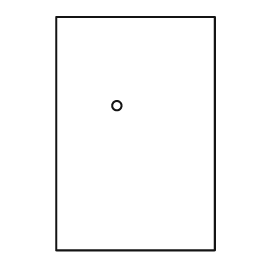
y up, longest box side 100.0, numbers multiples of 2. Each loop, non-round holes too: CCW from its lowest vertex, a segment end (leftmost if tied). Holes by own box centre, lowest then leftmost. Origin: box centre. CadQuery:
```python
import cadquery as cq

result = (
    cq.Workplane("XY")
    .moveTo(-34.0, -50.0)
    .lineTo(34.0, -50.0)
    .lineTo(34.0, 50.0)
    .lineTo(-34.0, 50.0)
    .close()
    .moveTo(-8.0, 12.0)
    .circle(2.0)
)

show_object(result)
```